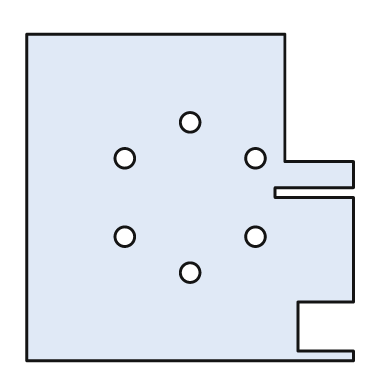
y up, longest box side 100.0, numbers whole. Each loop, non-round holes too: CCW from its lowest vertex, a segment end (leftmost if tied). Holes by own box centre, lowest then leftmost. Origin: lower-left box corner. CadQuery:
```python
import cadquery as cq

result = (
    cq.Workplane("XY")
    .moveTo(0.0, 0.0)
    .lineTo(100.0, 0.0)
    .lineTo(100.0, 3.0)
    .lineTo(83.0, 3.0)
    .lineTo(83.0, 18.0)
    .lineTo(100.0, 18.0)
    .lineTo(100.0, 50.0)
    .lineTo(76.0, 50.0)
    .lineTo(76.0, 53.0)
    .lineTo(100.0, 53.0)
    .lineTo(100.0, 61.0)
    .lineTo(79.0, 61.0)
    .lineTo(79.0, 100.0)
    .lineTo(0.0, 100.0)
    .close()
    .moveTo(50.0, 27.0)
    .circle(3.0)
    .moveTo(30.0, 38.0)
    .circle(3.0)
    .moveTo(70.0, 38.0)
    .circle(3.0)
    .moveTo(30.0, 62.0)
    .circle(3.0)
    .moveTo(70.0, 62.0)
    .circle(3.0)
    .moveTo(50.0, 73.0)
    .circle(3.0)
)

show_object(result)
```